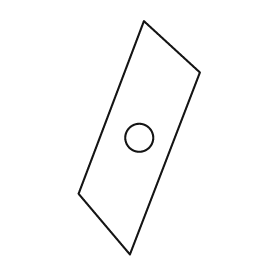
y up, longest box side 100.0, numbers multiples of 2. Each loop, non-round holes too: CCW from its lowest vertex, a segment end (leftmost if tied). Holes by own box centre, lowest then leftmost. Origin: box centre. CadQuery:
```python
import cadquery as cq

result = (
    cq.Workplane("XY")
    .moveTo(-4.0, -50.0)
    .lineTo(26.0, 28.0)
    .lineTo(2.0, 50.0)
    .lineTo(-26.0, -24.0)
    .close()
    .moveTo(0.0, 0.0)
    .circle(6.0)
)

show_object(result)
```